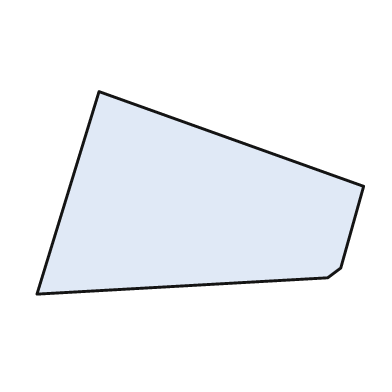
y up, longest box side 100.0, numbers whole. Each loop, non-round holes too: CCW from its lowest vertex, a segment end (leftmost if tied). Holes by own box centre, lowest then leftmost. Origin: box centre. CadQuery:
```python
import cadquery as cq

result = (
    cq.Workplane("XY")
    .moveTo(-50.0, -31.0)
    .lineTo(39.0, -26.0)
    .lineTo(43.0, -23.0)
    .lineTo(50.0, 2.0)
    .lineTo(-31.0, 31.0)
    .close()
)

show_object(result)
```